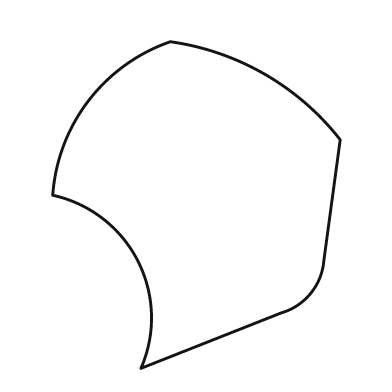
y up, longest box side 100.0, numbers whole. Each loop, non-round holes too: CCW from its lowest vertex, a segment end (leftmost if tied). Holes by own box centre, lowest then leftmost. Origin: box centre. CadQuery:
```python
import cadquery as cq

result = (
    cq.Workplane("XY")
    .moveTo(-17.0, -50.0)
    .lineTo(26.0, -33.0)
    .threePointArc((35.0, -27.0), (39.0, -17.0))
    .lineTo(44.0, 20.0)
    .threePointArc((21.0, 40.0), (-8.0, 50.0))
    .threePointArc((-33.0, 32.0), (-44.0, 3.0))
    .threePointArc((-18.0, -17.0), (-17.0, -50.0))
    .close()
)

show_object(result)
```